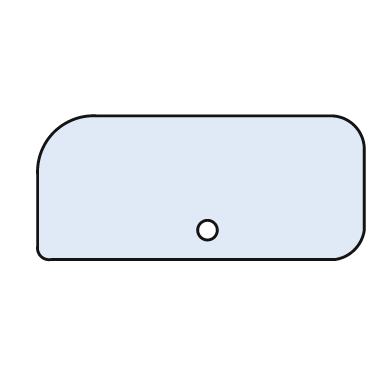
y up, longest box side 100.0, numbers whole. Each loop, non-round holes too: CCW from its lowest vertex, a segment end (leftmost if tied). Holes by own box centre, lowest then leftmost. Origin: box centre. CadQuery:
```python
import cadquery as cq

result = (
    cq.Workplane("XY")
    .moveTo(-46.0, -22.0)
    .lineTo(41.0, -22.0)
    .threePointArc((47.0, -19.0), (50.0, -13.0))
    .lineTo(50.0, 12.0)
    .threePointArc((47.0, 19.0), (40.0, 22.0))
    .lineTo(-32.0, 22.0)
    .threePointArc((-45.0, 17.0), (-50.0, 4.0))
    .lineTo(-50.0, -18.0)
    .threePointArc((-49.0, -21.0), (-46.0, -22.0))
    .close()
    .moveTo(2.0, -13.0)
    .circle(3.0)
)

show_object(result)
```